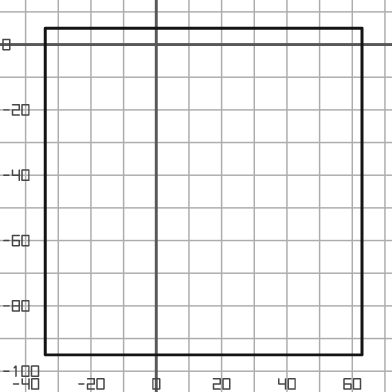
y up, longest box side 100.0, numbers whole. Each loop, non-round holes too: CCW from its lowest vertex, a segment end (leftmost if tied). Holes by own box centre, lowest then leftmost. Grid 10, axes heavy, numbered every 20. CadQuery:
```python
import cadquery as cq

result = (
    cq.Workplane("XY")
    .moveTo(-34.0, -95.0)
    .lineTo(63.0, -95.0)
    .lineTo(63.0, 5.0)
    .lineTo(-34.0, 5.0)
    .close()
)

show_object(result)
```